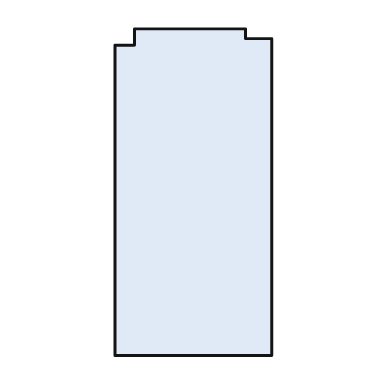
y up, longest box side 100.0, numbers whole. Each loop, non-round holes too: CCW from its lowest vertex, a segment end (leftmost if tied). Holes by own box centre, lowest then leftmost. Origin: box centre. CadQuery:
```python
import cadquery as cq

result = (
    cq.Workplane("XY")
    .moveTo(-24.0, -50.0)
    .lineTo(24.0, -50.0)
    .lineTo(24.0, 47.0)
    .lineTo(16.0, 47.0)
    .lineTo(16.0, 50.0)
    .lineTo(-18.0, 50.0)
    .lineTo(-18.0, 45.0)
    .lineTo(-24.0, 45.0)
    .close()
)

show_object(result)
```